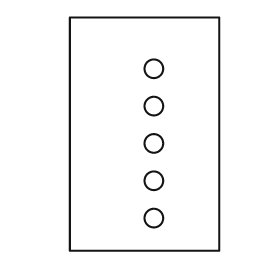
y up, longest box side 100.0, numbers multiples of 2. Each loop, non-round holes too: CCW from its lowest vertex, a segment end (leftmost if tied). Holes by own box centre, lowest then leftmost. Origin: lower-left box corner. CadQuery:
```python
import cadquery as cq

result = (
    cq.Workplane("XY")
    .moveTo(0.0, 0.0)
    .lineTo(64.0, 0.0)
    .lineTo(64.0, 100.0)
    .lineTo(0.0, 100.0)
    .close()
    .moveTo(36.0, 14.0)
    .circle(4.0)
    .moveTo(36.0, 30.0)
    .circle(4.0)
    .moveTo(36.0, 46.0)
    .circle(4.0)
    .moveTo(36.0, 62.0)
    .circle(4.0)
    .moveTo(36.0, 78.0)
    .circle(4.0)
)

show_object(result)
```